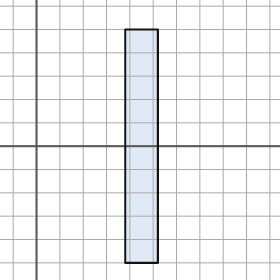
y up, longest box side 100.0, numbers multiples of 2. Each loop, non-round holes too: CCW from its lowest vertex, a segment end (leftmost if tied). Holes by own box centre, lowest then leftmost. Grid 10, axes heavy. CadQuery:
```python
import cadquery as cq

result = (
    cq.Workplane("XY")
    .moveTo(38.0, -50.0)
    .lineTo(52.0, -50.0)
    .lineTo(52.0, 50.0)
    .lineTo(38.0, 50.0)
    .close()
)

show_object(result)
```